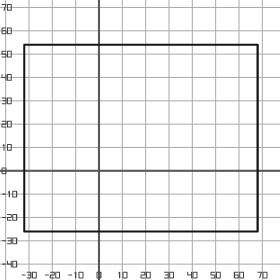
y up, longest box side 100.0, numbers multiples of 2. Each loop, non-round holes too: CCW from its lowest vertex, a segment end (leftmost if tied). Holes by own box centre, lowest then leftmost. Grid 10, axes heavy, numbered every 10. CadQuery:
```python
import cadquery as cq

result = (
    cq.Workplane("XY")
    .moveTo(-32.0, -26.0)
    .lineTo(68.0, -26.0)
    .lineTo(68.0, 54.0)
    .lineTo(-32.0, 54.0)
    .close()
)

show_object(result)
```